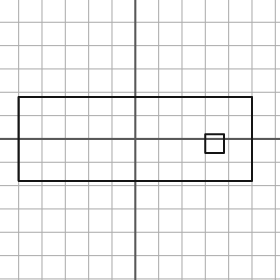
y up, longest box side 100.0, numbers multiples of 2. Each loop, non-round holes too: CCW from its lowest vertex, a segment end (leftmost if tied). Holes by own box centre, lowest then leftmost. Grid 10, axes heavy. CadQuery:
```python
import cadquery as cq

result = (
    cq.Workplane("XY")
    .moveTo(-50.0, -18.0)
    .lineTo(50.0, -18.0)
    .lineTo(50.0, 18.0)
    .lineTo(-50.0, 18.0)
    .close()
    .moveTo(30.0, -6.0)
    .lineTo(38.0, -6.0)
    .lineTo(38.0, 2.0)
    .lineTo(30.0, 2.0)
    .close()
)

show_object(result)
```